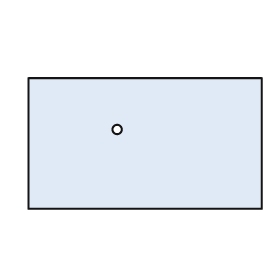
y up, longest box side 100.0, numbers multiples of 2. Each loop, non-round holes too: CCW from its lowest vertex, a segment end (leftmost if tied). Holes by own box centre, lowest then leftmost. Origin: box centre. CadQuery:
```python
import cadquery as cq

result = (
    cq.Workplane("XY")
    .moveTo(-50.0, -28.0)
    .lineTo(50.0, -28.0)
    .lineTo(50.0, 28.0)
    .lineTo(-50.0, 28.0)
    .close()
    .moveTo(-12.0, 6.0)
    .circle(2.0)
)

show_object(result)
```